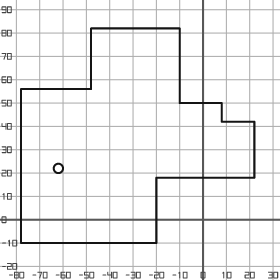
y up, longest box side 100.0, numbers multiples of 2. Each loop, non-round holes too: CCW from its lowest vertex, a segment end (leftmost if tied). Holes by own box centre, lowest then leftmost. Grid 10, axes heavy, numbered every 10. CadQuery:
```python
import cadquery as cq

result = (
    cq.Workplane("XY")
    .moveTo(-78.0, -10.0)
    .lineTo(-20.0, -10.0)
    .lineTo(-20.0, 18.0)
    .lineTo(22.0, 18.0)
    .lineTo(22.0, 42.0)
    .lineTo(8.0, 42.0)
    .lineTo(8.0, 50.0)
    .lineTo(-10.0, 50.0)
    .lineTo(-10.0, 82.0)
    .lineTo(-48.0, 82.0)
    .lineTo(-48.0, 56.0)
    .lineTo(-78.0, 56.0)
    .close()
    .moveTo(-62.0, 22.0)
    .circle(2.0)
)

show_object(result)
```